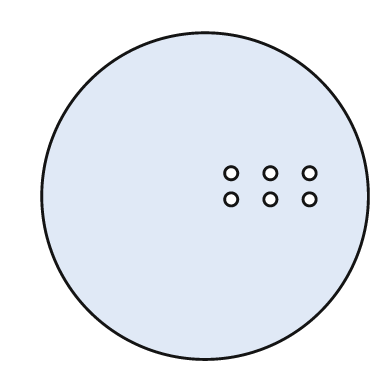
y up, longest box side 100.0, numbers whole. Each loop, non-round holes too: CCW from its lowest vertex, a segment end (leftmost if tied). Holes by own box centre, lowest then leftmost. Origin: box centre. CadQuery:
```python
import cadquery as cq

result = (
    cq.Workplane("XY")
    .moveTo(0.0, 0.0)
    .circle(50.0)
    .moveTo(8.0, -1.0)
    .circle(2.0)
    .moveTo(20.0, -1.0)
    .circle(2.0)
    .moveTo(32.0, -1.0)
    .circle(2.0)
    .moveTo(8.0, 7.0)
    .circle(2.0)
    .moveTo(20.0, 7.0)
    .circle(2.0)
    .moveTo(32.0, 7.0)
    .circle(2.0)
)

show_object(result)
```